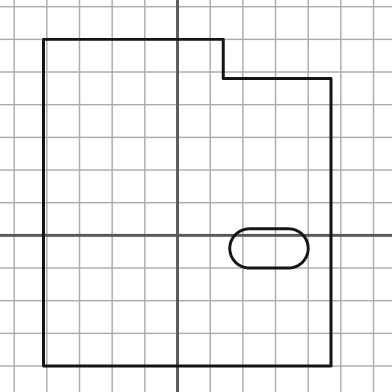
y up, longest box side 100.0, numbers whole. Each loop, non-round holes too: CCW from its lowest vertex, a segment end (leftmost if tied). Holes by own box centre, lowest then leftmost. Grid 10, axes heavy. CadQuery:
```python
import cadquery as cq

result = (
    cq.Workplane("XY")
    .moveTo(-41.0, -40.0)
    .lineTo(47.0, -40.0)
    .lineTo(47.0, 48.0)
    .lineTo(14.0, 48.0)
    .lineTo(14.0, 60.0)
    .lineTo(-41.0, 60.0)
    .close()
    .moveTo(22.0, -10.0)
    .lineTo(34.0, -10.0)
    .threePointArc((40.0, -4.0), (34.0, 2.0))
    .lineTo(22.0, 2.0)
    .threePointArc((16.0, -4.0), (22.0, -10.0))
    .close()
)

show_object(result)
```